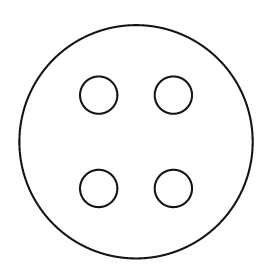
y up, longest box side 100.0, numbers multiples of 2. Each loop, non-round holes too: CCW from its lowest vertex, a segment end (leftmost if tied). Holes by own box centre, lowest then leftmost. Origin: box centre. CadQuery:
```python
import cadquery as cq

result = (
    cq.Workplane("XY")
    .moveTo(0.0, 0.0)
    .circle(50.0)
    .moveTo(-16.0, -20.0)
    .circle(8.0)
    .moveTo(16.0, -20.0)
    .circle(8.0)
    .moveTo(-16.0, 20.0)
    .circle(8.0)
    .moveTo(16.0, 20.0)
    .circle(8.0)
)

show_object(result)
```